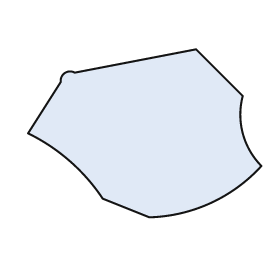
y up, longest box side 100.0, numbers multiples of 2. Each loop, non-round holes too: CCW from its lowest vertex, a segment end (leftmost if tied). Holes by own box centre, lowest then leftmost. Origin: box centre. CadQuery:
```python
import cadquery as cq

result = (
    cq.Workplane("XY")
    .moveTo(2.0, -36.0)
    .threePointArc((28.0, -30.0), (50.0, -14.0))
    .threePointArc((42.0, 0.0), (42.0, 16.0))
    .lineTo(22.0, 36.0)
    .lineTo(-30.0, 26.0)
    .threePointArc((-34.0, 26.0), (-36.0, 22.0))
    .lineTo(-50.0, 0.0)
    .threePointArc((-32.0, -12.0), (-18.0, -28.0))
    .close()
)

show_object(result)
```